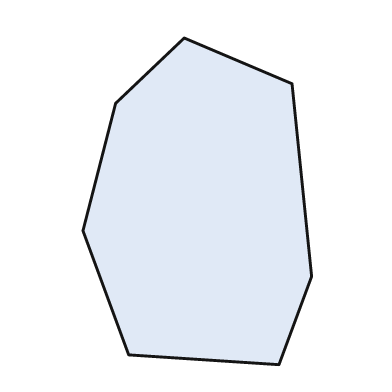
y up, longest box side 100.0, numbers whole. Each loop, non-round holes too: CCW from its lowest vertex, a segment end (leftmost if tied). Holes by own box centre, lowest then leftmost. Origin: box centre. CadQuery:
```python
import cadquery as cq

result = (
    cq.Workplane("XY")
    .moveTo(25.0, -50.0)
    .lineTo(35.0, -23.0)
    .lineTo(29.0, 36.0)
    .lineTo(-4.0, 50.0)
    .lineTo(-25.0, 30.0)
    .lineTo(-35.0, -9.0)
    .lineTo(-21.0, -47.0)
    .close()
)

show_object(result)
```